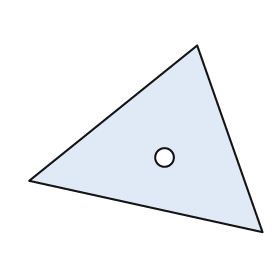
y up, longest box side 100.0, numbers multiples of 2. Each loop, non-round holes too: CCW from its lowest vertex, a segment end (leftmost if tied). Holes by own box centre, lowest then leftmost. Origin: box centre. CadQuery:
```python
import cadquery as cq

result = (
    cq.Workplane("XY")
    .moveTo(50.0, -40.0)
    .lineTo(22.0, 40.0)
    .lineTo(-50.0, -18.0)
    .close()
    .moveTo(8.0, -8.0)
    .circle(4.0)
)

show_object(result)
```